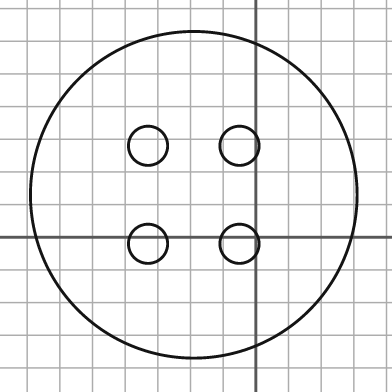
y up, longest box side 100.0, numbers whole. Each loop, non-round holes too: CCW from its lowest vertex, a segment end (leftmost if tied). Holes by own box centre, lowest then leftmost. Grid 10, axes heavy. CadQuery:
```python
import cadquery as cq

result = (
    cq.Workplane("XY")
    .moveTo(-19.0, 13.0)
    .circle(50.0)
    .moveTo(-33.0, -2.0)
    .circle(6.0)
    .moveTo(-5.0, -2.0)
    .circle(6.0)
    .moveTo(-33.0, 28.0)
    .circle(6.0)
    .moveTo(-5.0, 28.0)
    .circle(6.0)
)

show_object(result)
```